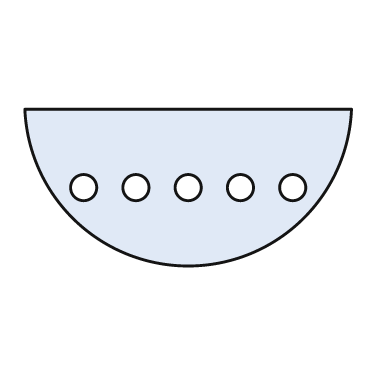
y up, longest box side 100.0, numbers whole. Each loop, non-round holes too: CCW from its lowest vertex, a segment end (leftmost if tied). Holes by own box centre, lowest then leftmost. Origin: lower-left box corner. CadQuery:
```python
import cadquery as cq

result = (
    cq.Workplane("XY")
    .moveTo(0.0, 48.0)
    .threePointArc((50.0, 0.0), (100.0, 48.0))
    .close()
    .moveTo(18.0, 24.0)
    .circle(4.0)
    .moveTo(34.0, 24.0)
    .circle(4.0)
    .moveTo(50.0, 24.0)
    .circle(4.0)
    .moveTo(66.0, 24.0)
    .circle(4.0)
    .moveTo(82.0, 24.0)
    .circle(4.0)
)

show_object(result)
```